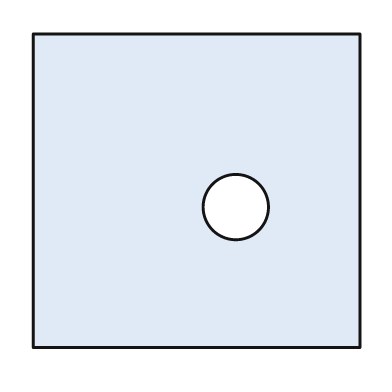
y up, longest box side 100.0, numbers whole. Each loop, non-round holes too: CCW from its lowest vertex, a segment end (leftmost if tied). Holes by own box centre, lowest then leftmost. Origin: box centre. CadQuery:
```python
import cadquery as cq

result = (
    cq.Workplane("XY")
    .moveTo(-50.0, -48.0)
    .lineTo(50.0, -48.0)
    .lineTo(50.0, 48.0)
    .lineTo(-50.0, 48.0)
    .close()
    .moveTo(12.0, -5.0)
    .circle(10.0)
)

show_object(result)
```